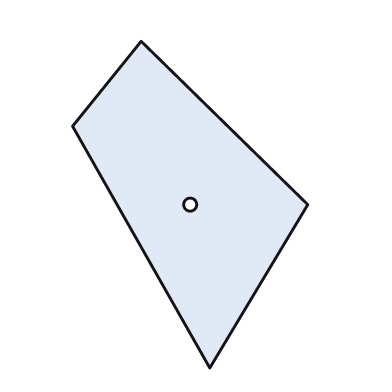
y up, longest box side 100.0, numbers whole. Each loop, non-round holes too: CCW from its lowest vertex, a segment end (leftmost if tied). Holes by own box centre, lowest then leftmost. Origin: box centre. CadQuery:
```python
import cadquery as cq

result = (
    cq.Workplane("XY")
    .moveTo(6.0, -50.0)
    .lineTo(36.0, 0.0)
    .lineTo(-15.0, 50.0)
    .lineTo(-36.0, 24.0)
    .close()
    .moveTo(0.0, 0.0)
    .circle(2.0)
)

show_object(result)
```